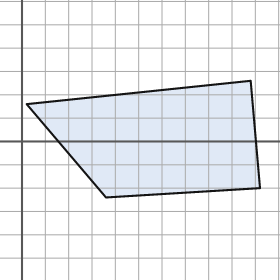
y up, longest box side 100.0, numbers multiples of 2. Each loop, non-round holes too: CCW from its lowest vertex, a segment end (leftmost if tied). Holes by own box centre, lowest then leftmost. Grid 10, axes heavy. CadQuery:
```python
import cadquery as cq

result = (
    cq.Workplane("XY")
    .moveTo(36.0, -24.0)
    .lineTo(102.0, -20.0)
    .lineTo(98.0, 26.0)
    .lineTo(2.0, 16.0)
    .close()
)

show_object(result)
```